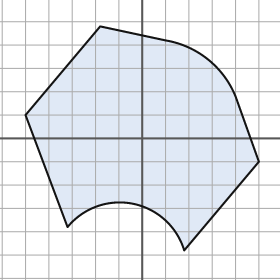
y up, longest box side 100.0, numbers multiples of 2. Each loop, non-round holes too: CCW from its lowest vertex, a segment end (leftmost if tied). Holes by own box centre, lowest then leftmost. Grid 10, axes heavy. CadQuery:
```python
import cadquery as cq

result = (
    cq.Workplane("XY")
    .moveTo(18.0, -48.0)
    .lineTo(50.0, -10.0)
    .lineTo(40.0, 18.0)
    .threePointArc((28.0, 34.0), (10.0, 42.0))
    .lineTo(-18.0, 48.0)
    .lineTo(-50.0, 10.0)
    .lineTo(-32.0, -38.0)
    .threePointArc((-4.0, -28.0), (18.0, -48.0))
    .close()
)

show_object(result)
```